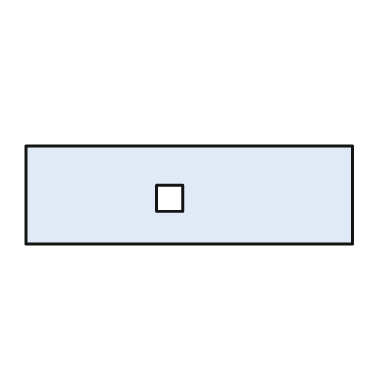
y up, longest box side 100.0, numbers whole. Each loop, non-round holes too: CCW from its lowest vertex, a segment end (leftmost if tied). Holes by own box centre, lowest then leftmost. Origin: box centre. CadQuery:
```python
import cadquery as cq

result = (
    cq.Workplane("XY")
    .moveTo(-50.0, -15.0)
    .lineTo(50.0, -15.0)
    .lineTo(50.0, 15.0)
    .lineTo(-50.0, 15.0)
    .close()
    .moveTo(-10.0, -5.0)
    .lineTo(-2.0, -5.0)
    .lineTo(-2.0, 3.0)
    .lineTo(-10.0, 3.0)
    .close()
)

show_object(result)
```